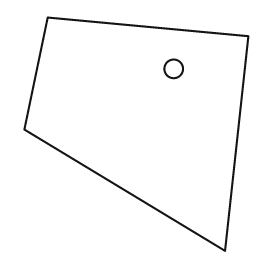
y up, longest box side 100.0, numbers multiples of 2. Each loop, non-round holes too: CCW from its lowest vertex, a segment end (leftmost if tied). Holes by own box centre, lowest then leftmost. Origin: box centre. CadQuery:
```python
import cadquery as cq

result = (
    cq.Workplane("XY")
    .moveTo(38.0, -50.0)
    .lineTo(48.0, 42.0)
    .lineTo(-38.0, 50.0)
    .lineTo(-48.0, 2.0)
    .close()
    .moveTo(16.0, 28.0)
    .circle(4.0)
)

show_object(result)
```